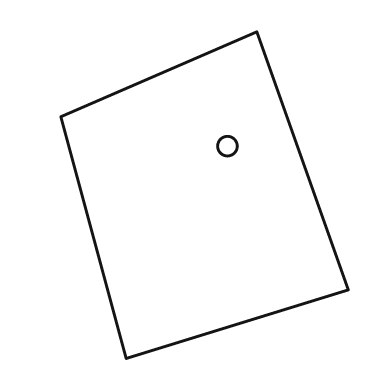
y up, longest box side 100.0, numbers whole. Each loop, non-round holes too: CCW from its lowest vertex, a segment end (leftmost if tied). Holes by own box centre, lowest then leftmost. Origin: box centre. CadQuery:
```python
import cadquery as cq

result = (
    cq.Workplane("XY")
    .moveTo(-24.0, -50.0)
    .lineTo(44.0, -29.0)
    .lineTo(16.0, 50.0)
    .lineTo(-44.0, 24.0)
    .close()
    .moveTo(7.0, 15.0)
    .circle(3.0)
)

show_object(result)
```